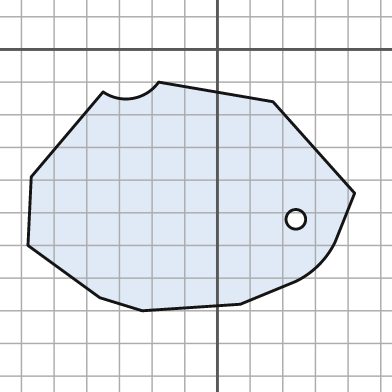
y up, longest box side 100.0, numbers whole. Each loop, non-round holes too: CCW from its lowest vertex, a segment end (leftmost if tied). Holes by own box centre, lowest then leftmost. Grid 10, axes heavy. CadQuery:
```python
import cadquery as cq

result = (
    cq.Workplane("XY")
    .moveTo(-23.0, -80.0)
    .lineTo(7.0, -78.0)
    .lineTo(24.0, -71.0)
    .threePointArc((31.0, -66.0), (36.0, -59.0))
    .lineTo(42.0, -44.0)
    .lineTo(17.0, -16.0)
    .lineTo(-18.0, -10.0)
    .threePointArc((-26.0, -15.0), (-35.0, -13.0))
    .lineTo(-57.0, -39.0)
    .lineTo(-58.0, -60.0)
    .lineTo(-36.0, -76.0)
    .close()
    .moveTo(24.0, -52.0)
    .circle(3.0)
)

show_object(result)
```